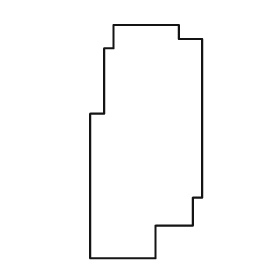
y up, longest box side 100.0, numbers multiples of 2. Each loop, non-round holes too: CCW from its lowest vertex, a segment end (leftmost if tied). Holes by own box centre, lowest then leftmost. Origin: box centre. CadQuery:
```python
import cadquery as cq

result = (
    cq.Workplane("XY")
    .moveTo(-24.0, -50.0)
    .lineTo(4.0, -50.0)
    .lineTo(4.0, -36.0)
    .lineTo(20.0, -36.0)
    .lineTo(20.0, -24.0)
    .lineTo(24.0, -24.0)
    .lineTo(24.0, 44.0)
    .lineTo(14.0, 44.0)
    .lineTo(14.0, 50.0)
    .lineTo(-14.0, 50.0)
    .lineTo(-14.0, 40.0)
    .lineTo(-18.0, 40.0)
    .lineTo(-18.0, 12.0)
    .lineTo(-24.0, 12.0)
    .close()
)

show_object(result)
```